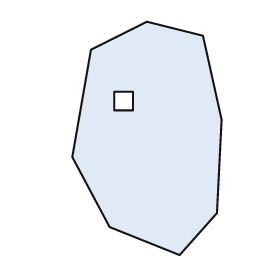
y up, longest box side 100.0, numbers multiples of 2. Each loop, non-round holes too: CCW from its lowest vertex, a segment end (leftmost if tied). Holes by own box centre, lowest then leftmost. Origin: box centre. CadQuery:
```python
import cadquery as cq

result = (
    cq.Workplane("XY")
    .moveTo(14.0, -50.0)
    .lineTo(30.0, -32.0)
    .lineTo(32.0, 8.0)
    .lineTo(24.0, 44.0)
    .lineTo(0.0, 50.0)
    .lineTo(-24.0, 38.0)
    .lineTo(-32.0, -8.0)
    .lineTo(-16.0, -38.0)
    .close()
    .moveTo(-14.0, 12.0)
    .lineTo(-6.0, 12.0)
    .lineTo(-6.0, 20.0)
    .lineTo(-14.0, 20.0)
    .close()
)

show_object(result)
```